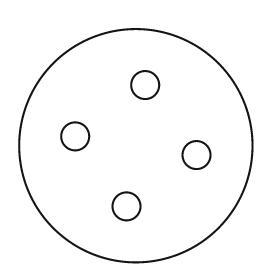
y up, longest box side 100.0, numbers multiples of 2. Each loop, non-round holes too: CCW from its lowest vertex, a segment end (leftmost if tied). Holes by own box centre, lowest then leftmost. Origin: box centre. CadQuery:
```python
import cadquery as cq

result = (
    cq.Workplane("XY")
    .moveTo(0.0, 0.0)
    .circle(50.0)
    .moveTo(-4.0, -26.0)
    .circle(6.0)
    .moveTo(26.0, -4.0)
    .circle(6.0)
    .moveTo(-26.0, 4.0)
    .circle(6.0)
    .moveTo(4.0, 26.0)
    .circle(6.0)
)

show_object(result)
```